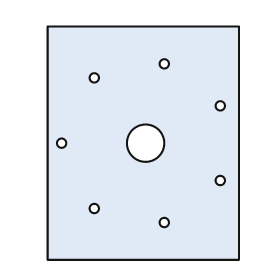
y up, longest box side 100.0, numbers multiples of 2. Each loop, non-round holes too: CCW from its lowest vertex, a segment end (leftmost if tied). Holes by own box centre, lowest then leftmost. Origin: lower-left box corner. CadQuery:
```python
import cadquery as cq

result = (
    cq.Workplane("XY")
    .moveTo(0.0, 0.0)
    .lineTo(82.0, 0.0)
    .lineTo(82.0, 100.0)
    .lineTo(0.0, 100.0)
    .close()
    .moveTo(50.0, 16.0)
    .circle(2.0)
    .moveTo(20.0, 22.0)
    .circle(2.0)
    .moveTo(74.0, 34.0)
    .circle(2.0)
    .moveTo(6.0, 50.0)
    .circle(2.0)
    .moveTo(42.0, 50.0)
    .circle(8.0)
    .moveTo(74.0, 66.0)
    .circle(2.0)
    .moveTo(20.0, 78.0)
    .circle(2.0)
    .moveTo(50.0, 84.0)
    .circle(2.0)
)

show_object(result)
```